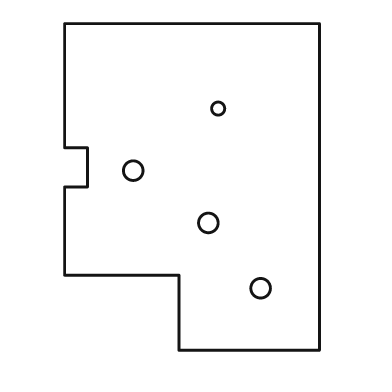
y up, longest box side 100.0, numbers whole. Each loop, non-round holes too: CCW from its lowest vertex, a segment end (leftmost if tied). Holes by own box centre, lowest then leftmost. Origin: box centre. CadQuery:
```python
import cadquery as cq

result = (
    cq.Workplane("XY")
    .moveTo(-4.0, -50.0)
    .lineTo(39.0, -50.0)
    .lineTo(39.0, 50.0)
    .lineTo(-39.0, 50.0)
    .lineTo(-39.0, 12.0)
    .lineTo(-32.0, 12.0)
    .lineTo(-32.0, 0.0)
    .lineTo(-39.0, 0.0)
    .lineTo(-39.0, -27.0)
    .lineTo(-4.0, -27.0)
    .close()
    .moveTo(21.0, -31.0)
    .circle(3.0)
    .moveTo(5.0, -11.0)
    .circle(3.0)
    .moveTo(-18.0, 5.0)
    .circle(3.0)
    .moveTo(8.0, 24.0)
    .circle(2.0)
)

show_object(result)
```